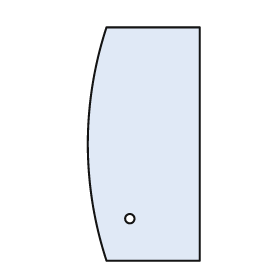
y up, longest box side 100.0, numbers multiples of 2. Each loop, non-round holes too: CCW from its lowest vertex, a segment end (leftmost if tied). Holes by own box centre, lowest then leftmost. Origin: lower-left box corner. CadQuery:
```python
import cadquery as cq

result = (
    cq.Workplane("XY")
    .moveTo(8.0, 0.0)
    .lineTo(48.0, 0.0)
    .lineTo(48.0, 100.0)
    .lineTo(8.0, 100.0)
    .threePointArc((0.0, 50.0), (8.0, 0.0))
    .close()
    .moveTo(18.0, 18.0)
    .circle(2.0)
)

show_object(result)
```